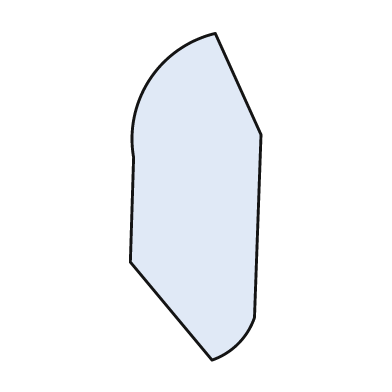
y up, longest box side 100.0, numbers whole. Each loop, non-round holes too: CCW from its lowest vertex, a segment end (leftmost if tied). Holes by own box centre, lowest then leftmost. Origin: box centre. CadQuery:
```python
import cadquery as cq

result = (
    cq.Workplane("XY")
    .moveTo(5.0, -50.0)
    .threePointArc((13.0, -45.0), (18.0, -37.0))
    .lineTo(20.0, 19.0)
    .lineTo(6.0, 50.0)
    .threePointArc((-14.0, 36.0), (-19.0, 12.0))
    .lineTo(-20.0, -20.0)
    .close()
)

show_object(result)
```